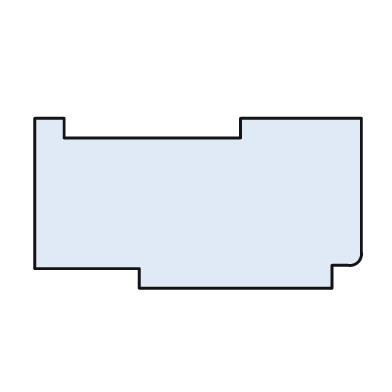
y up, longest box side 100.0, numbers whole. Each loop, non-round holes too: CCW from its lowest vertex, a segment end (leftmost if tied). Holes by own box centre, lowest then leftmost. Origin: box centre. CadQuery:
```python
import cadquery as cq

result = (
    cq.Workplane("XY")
    .moveTo(-18.0, -26.0)
    .lineTo(41.0, -26.0)
    .lineTo(41.0, -19.0)
    .lineTo(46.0, -19.0)
    .threePointArc((49.0, -18.0), (50.0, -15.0))
    .lineTo(50.0, 26.0)
    .lineTo(13.0, 26.0)
    .lineTo(13.0, 20.0)
    .lineTo(-41.0, 20.0)
    .lineTo(-41.0, 26.0)
    .lineTo(-50.0, 26.0)
    .lineTo(-50.0, -20.0)
    .lineTo(-18.0, -20.0)
    .close()
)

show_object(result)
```